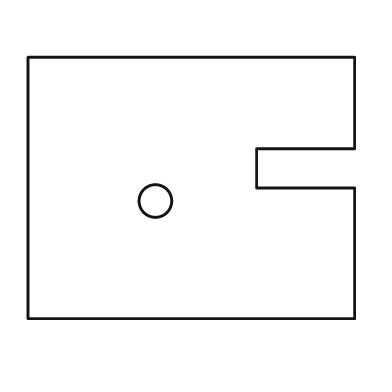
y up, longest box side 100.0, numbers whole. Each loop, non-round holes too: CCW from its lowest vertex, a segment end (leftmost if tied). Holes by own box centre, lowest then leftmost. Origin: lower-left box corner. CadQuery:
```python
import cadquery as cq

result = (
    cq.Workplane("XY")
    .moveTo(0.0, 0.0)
    .lineTo(100.0, 0.0)
    .lineTo(100.0, 40.0)
    .lineTo(70.0, 40.0)
    .lineTo(70.0, 52.0)
    .lineTo(100.0, 52.0)
    .lineTo(100.0, 80.0)
    .lineTo(0.0, 80.0)
    .close()
    .moveTo(39.0, 36.0)
    .circle(5.0)
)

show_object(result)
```